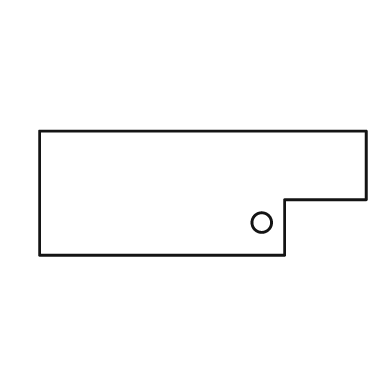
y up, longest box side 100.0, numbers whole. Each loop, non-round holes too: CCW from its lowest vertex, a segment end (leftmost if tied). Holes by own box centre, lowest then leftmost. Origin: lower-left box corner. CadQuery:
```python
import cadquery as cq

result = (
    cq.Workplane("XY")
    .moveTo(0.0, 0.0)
    .lineTo(75.0, 0.0)
    .lineTo(75.0, 17.0)
    .lineTo(100.0, 17.0)
    .lineTo(100.0, 38.0)
    .lineTo(0.0, 38.0)
    .close()
    .moveTo(68.0, 10.0)
    .circle(3.0)
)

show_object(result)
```